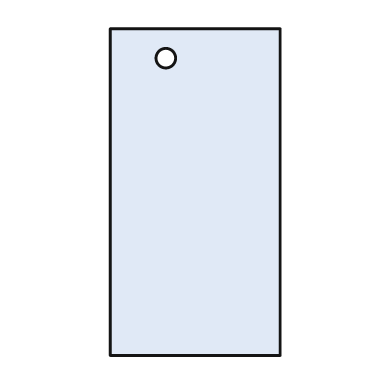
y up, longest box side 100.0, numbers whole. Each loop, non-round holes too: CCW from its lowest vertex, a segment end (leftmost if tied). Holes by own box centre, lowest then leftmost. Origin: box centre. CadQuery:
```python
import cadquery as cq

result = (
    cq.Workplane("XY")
    .moveTo(-26.0, -50.0)
    .lineTo(26.0, -50.0)
    .lineTo(26.0, 50.0)
    .lineTo(-26.0, 50.0)
    .close()
    .moveTo(-9.0, 41.0)
    .circle(3.0)
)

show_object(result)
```